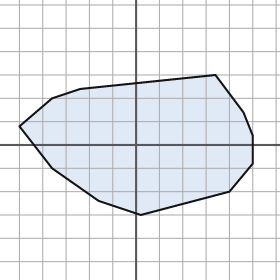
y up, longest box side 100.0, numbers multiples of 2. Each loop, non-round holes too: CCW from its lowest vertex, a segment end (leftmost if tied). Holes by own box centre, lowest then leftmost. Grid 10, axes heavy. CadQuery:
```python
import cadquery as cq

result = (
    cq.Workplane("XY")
    .moveTo(2.0, -30.0)
    .lineTo(40.0, -20.0)
    .lineTo(50.0, -8.0)
    .lineTo(50.0, 4.0)
    .lineTo(46.0, 14.0)
    .lineTo(34.0, 30.0)
    .lineTo(-24.0, 24.0)
    .lineTo(-36.0, 20.0)
    .lineTo(-50.0, 8.0)
    .lineTo(-36.0, -10.0)
    .lineTo(-16.0, -24.0)
    .close()
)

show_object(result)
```